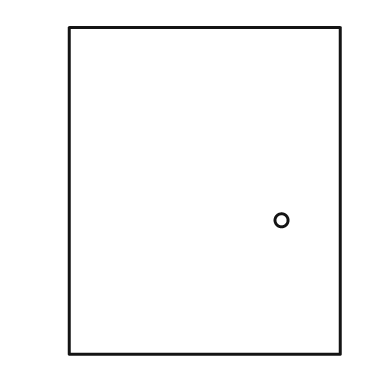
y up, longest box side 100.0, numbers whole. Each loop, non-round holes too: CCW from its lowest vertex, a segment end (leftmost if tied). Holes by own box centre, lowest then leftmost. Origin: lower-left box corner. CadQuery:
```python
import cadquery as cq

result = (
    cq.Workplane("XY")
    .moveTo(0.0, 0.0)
    .lineTo(83.0, 0.0)
    .lineTo(83.0, 100.0)
    .lineTo(0.0, 100.0)
    .close()
    .moveTo(65.0, 41.0)
    .circle(2.0)
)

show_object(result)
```